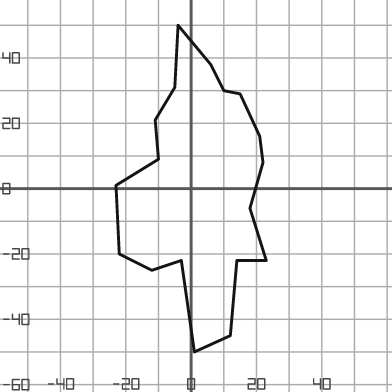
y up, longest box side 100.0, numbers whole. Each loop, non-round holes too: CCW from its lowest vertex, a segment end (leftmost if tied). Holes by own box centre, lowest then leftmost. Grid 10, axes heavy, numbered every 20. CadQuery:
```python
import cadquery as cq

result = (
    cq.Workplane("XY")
    .moveTo(1.0, -50.0)
    .lineTo(12.0, -45.0)
    .lineTo(14.0, -22.0)
    .lineTo(23.0, -22.0)
    .lineTo(18.0, -6.0)
    .lineTo(22.0, 8.0)
    .lineTo(21.0, 16.0)
    .lineTo(15.0, 29.0)
    .lineTo(10.0, 30.0)
    .lineTo(6.0, 38.0)
    .lineTo(-4.0, 50.0)
    .lineTo(-5.0, 31.0)
    .lineTo(-11.0, 21.0)
    .lineTo(-10.0, 9.0)
    .lineTo(-23.0, 1.0)
    .lineTo(-22.0, -20.0)
    .lineTo(-12.0, -25.0)
    .lineTo(-3.0, -22.0)
    .close()
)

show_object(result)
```